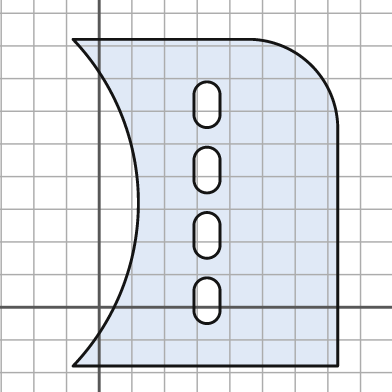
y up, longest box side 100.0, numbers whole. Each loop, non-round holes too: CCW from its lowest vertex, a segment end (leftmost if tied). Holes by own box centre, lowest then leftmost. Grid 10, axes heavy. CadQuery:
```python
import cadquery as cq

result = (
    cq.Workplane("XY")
    .moveTo(-8.0, -18.0)
    .lineTo(73.0, -18.0)
    .lineTo(73.0, 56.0)
    .threePointArc((65.0, 74.0), (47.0, 82.0))
    .lineTo(-8.0, 82.0)
    .threePointArc((12.0, 32.0), (-8.0, -18.0))
    .close()
    .moveTo(29.0, -1.0)
    .threePointArc((33.0, -5.0), (37.0, -1.0))
    .lineTo(37.0, 5.0)
    .threePointArc((33.0, 9.0), (29.0, 5.0))
    .close()
    .moveTo(29.0, 19.0)
    .threePointArc((33.0, 15.0), (37.0, 19.0))
    .lineTo(37.0, 25.0)
    .threePointArc((33.0, 29.0), (29.0, 25.0))
    .close()
    .moveTo(29.0, 39.0)
    .threePointArc((33.0, 35.0), (37.0, 39.0))
    .lineTo(37.0, 45.0)
    .threePointArc((33.0, 49.0), (29.0, 45.0))
    .close()
    .moveTo(29.0, 59.0)
    .threePointArc((33.0, 55.0), (37.0, 59.0))
    .lineTo(37.0, 65.0)
    .threePointArc((33.0, 69.0), (29.0, 65.0))
    .close()
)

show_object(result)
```